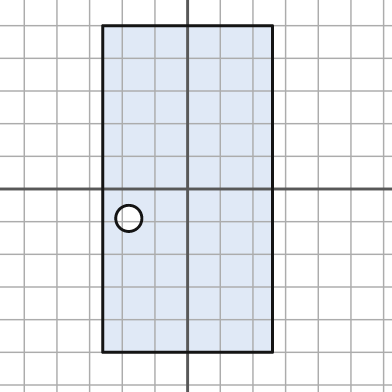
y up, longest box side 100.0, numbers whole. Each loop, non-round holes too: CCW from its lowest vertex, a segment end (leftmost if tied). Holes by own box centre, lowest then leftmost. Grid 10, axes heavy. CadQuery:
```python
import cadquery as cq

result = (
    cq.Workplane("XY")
    .moveTo(-26.0, -50.0)
    .lineTo(26.0, -50.0)
    .lineTo(26.0, 50.0)
    .lineTo(-26.0, 50.0)
    .close()
    .moveTo(-18.0, -9.0)
    .circle(4.0)
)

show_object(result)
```